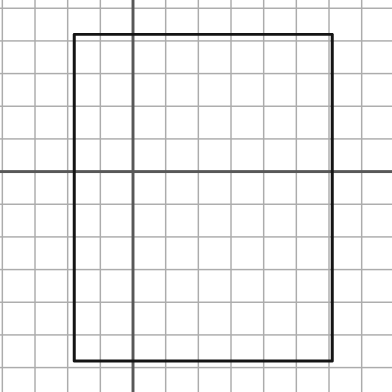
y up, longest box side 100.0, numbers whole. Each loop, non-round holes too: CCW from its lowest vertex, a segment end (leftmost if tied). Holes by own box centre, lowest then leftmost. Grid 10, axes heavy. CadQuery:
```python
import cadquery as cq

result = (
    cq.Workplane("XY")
    .moveTo(-18.0, -58.0)
    .lineTo(61.0, -58.0)
    .lineTo(61.0, 42.0)
    .lineTo(-18.0, 42.0)
    .close()
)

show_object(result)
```